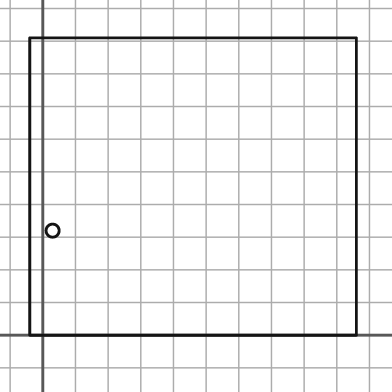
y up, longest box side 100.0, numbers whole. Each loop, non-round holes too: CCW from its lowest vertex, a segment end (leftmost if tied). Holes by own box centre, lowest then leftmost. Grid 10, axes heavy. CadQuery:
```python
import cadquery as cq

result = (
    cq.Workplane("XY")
    .moveTo(-4.0, 0.0)
    .lineTo(96.0, 0.0)
    .lineTo(96.0, 91.0)
    .lineTo(-4.0, 91.0)
    .close()
    .moveTo(3.0, 32.0)
    .circle(2.0)
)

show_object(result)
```